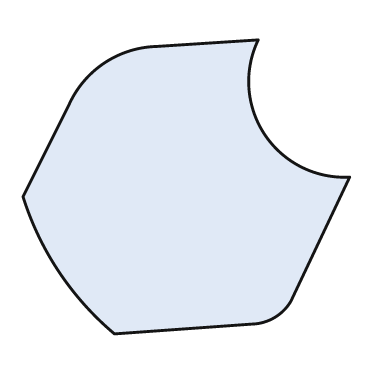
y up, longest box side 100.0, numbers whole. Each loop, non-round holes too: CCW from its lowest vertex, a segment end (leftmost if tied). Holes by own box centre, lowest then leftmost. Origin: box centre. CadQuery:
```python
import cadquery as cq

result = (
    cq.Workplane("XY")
    .moveTo(-22.0, -45.0)
    .lineTo(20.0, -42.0)
    .threePointArc((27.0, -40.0), (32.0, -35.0))
    .lineTo(50.0, 3.0)
    .threePointArc((24.0, 16.0), (22.0, 45.0))
    .lineTo(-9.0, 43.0)
    .threePointArc((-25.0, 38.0), (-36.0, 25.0))
    .lineTo(-50.0, -3.0)
    .threePointArc((-39.0, -26.0), (-22.0, -45.0))
    .close()
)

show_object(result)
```